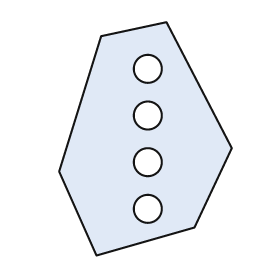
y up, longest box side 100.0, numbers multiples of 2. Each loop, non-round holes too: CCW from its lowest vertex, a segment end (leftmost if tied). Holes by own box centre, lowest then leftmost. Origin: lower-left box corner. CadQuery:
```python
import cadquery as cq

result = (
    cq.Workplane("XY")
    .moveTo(16.0, 0.0)
    .lineTo(58.0, 12.0)
    .lineTo(74.0, 46.0)
    .lineTo(46.0, 100.0)
    .lineTo(18.0, 94.0)
    .lineTo(0.0, 36.0)
    .close()
    .moveTo(38.0, 20.0)
    .circle(6.0)
    .moveTo(38.0, 40.0)
    .circle(6.0)
    .moveTo(38.0, 60.0)
    .circle(6.0)
    .moveTo(38.0, 80.0)
    .circle(6.0)
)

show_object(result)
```